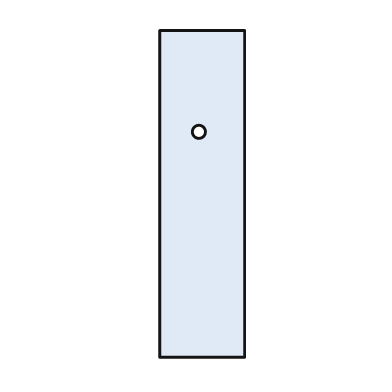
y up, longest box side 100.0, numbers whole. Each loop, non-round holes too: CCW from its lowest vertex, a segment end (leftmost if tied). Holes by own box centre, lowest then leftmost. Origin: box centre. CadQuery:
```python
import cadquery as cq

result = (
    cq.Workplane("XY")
    .moveTo(-13.0, -50.0)
    .lineTo(13.0, -50.0)
    .lineTo(13.0, 50.0)
    .lineTo(-13.0, 50.0)
    .close()
    .moveTo(-1.0, 19.0)
    .circle(2.0)
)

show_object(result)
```